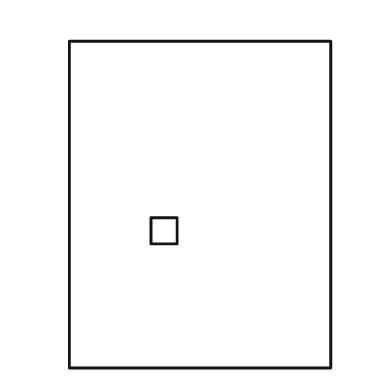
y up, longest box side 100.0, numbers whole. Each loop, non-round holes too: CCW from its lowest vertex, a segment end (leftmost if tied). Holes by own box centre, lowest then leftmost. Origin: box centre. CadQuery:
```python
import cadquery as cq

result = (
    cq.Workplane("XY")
    .moveTo(-40.0, -50.0)
    .lineTo(40.0, -50.0)
    .lineTo(40.0, 50.0)
    .lineTo(-40.0, 50.0)
    .close()
    .moveTo(-15.0, -12.0)
    .lineTo(-7.0, -12.0)
    .lineTo(-7.0, -4.0)
    .lineTo(-15.0, -4.0)
    .close()
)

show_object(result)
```